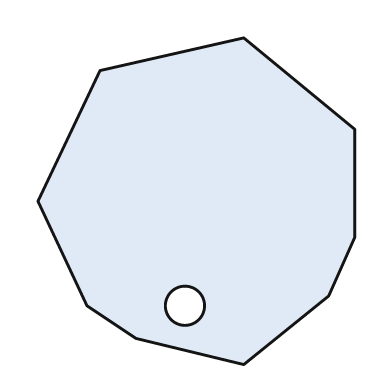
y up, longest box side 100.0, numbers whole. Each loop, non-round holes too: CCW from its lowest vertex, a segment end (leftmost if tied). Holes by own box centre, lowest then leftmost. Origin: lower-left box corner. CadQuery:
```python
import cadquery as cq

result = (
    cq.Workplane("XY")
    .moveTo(63.0, 0.0)
    .lineTo(89.0, 21.0)
    .lineTo(97.0, 39.0)
    .lineTo(97.0, 72.0)
    .lineTo(63.0, 100.0)
    .lineTo(19.0, 90.0)
    .lineTo(0.0, 50.0)
    .lineTo(15.0, 18.0)
    .lineTo(30.0, 8.0)
    .close()
    .moveTo(45.0, 18.0)
    .circle(6.0)
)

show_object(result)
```